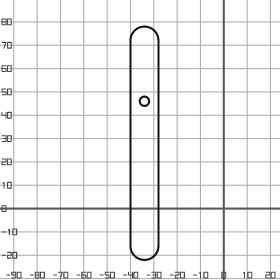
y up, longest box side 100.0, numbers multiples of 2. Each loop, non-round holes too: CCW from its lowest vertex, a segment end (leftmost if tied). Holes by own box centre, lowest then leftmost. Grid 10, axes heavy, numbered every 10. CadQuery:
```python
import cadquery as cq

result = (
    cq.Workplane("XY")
    .moveTo(-40.0, -16.0)
    .threePointArc((-34.0, -22.0), (-28.0, -16.0))
    .lineTo(-28.0, 72.0)
    .threePointArc((-34.0, 78.0), (-40.0, 72.0))
    .close()
    .moveTo(-34.0, 46.0)
    .circle(2.0)
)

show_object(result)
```